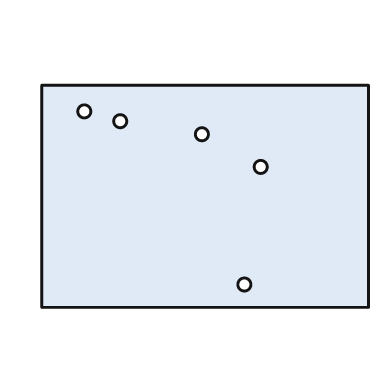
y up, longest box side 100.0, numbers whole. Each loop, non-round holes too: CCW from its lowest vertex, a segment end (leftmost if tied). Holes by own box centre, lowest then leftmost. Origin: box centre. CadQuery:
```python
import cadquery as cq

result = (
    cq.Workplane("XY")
    .moveTo(-50.0, -34.0)
    .lineTo(50.0, -34.0)
    .lineTo(50.0, 34.0)
    .lineTo(-50.0, 34.0)
    .close()
    .moveTo(12.0, -27.0)
    .circle(2.0)
    .moveTo(17.0, 9.0)
    .circle(2.0)
    .moveTo(-1.0, 19.0)
    .circle(2.0)
    .moveTo(-26.0, 23.0)
    .circle(2.0)
    .moveTo(-37.0, 26.0)
    .circle(2.0)
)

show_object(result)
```